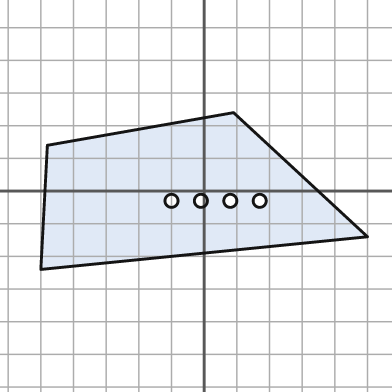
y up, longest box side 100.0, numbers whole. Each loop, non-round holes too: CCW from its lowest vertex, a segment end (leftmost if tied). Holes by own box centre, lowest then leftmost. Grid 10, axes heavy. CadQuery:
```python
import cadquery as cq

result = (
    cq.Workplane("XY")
    .moveTo(-50.0, -24.0)
    .lineTo(50.0, -14.0)
    .lineTo(9.0, 24.0)
    .lineTo(-48.0, 14.0)
    .close()
    .moveTo(-10.0, -3.0)
    .circle(2.0)
    .moveTo(-1.0, -3.0)
    .circle(2.0)
    .moveTo(8.0, -3.0)
    .circle(2.0)
    .moveTo(17.0, -3.0)
    .circle(2.0)
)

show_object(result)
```